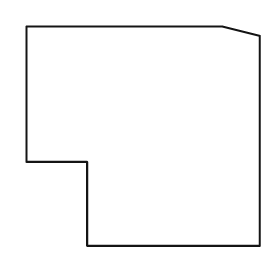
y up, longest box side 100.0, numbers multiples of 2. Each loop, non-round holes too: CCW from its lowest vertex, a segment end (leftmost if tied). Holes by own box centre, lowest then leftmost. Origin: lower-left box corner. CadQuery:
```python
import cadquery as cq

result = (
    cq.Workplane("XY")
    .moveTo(26.0, 0.0)
    .lineTo(100.0, 0.0)
    .lineTo(100.0, 90.0)
    .lineTo(84.0, 94.0)
    .lineTo(0.0, 94.0)
    .lineTo(0.0, 36.0)
    .lineTo(26.0, 36.0)
    .close()
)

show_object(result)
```